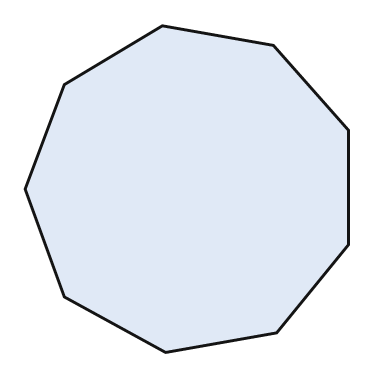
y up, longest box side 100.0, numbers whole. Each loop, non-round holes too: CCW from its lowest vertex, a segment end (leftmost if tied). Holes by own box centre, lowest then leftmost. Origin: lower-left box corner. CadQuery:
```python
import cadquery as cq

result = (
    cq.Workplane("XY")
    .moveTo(43.0, 0.0)
    .lineTo(77.0, 6.0)
    .lineTo(99.0, 33.0)
    .lineTo(99.0, 68.0)
    .lineTo(76.0, 94.0)
    .lineTo(42.0, 100.0)
    .lineTo(12.0, 82.0)
    .lineTo(0.0, 50.0)
    .lineTo(12.0, 17.0)
    .close()
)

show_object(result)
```